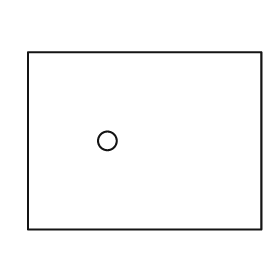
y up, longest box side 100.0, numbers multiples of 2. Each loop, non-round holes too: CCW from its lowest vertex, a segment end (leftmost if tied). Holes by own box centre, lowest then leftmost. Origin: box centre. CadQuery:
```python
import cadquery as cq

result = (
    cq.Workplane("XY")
    .moveTo(-50.0, -38.0)
    .lineTo(50.0, -38.0)
    .lineTo(50.0, 38.0)
    .lineTo(-50.0, 38.0)
    .close()
    .moveTo(-16.0, 0.0)
    .circle(4.0)
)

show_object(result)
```